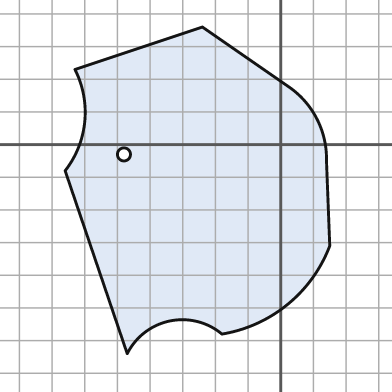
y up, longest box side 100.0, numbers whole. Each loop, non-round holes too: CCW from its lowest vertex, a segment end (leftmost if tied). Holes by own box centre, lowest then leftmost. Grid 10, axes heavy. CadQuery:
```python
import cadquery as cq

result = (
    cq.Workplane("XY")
    .moveTo(-47.0, -64.0)
    .threePointArc((-34.0, -54.0), (-18.0, -58.0))
    .threePointArc((2.0, -49.0), (15.0, -31.0))
    .lineTo(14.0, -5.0)
    .threePointArc((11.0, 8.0), (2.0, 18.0))
    .lineTo(-24.0, 36.0)
    .lineTo(-63.0, 23.0)
    .threePointArc((-60.0, 7.0), (-66.0, -8.0))
    .close()
    .moveTo(-48.0, -3.0)
    .circle(2.0)
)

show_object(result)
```